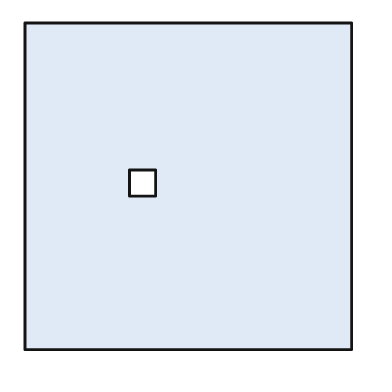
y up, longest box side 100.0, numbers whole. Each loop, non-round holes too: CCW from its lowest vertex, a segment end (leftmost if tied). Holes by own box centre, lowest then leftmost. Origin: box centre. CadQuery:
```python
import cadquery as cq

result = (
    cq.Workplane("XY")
    .moveTo(-50.0, -50.0)
    .lineTo(50.0, -50.0)
    .lineTo(50.0, 50.0)
    .lineTo(-50.0, 50.0)
    .close()
    .moveTo(-18.0, -3.0)
    .lineTo(-10.0, -3.0)
    .lineTo(-10.0, 5.0)
    .lineTo(-18.0, 5.0)
    .close()
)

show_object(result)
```